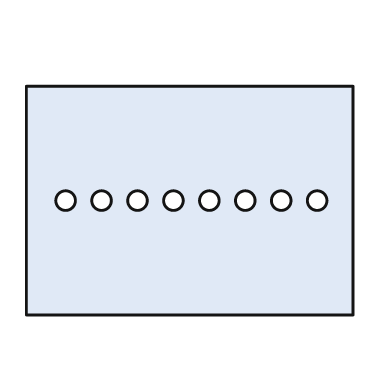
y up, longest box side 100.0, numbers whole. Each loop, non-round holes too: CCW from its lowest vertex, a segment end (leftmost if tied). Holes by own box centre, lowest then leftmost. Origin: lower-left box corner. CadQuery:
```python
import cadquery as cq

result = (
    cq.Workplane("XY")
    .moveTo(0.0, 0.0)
    .lineTo(100.0, 0.0)
    .lineTo(100.0, 70.0)
    .lineTo(0.0, 70.0)
    .close()
    .moveTo(12.0, 35.0)
    .circle(3.0)
    .moveTo(23.0, 35.0)
    .circle(3.0)
    .moveTo(34.0, 35.0)
    .circle(3.0)
    .moveTo(45.0, 35.0)
    .circle(3.0)
    .moveTo(56.0, 35.0)
    .circle(3.0)
    .moveTo(67.0, 35.0)
    .circle(3.0)
    .moveTo(78.0, 35.0)
    .circle(3.0)
    .moveTo(89.0, 35.0)
    .circle(3.0)
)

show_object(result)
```